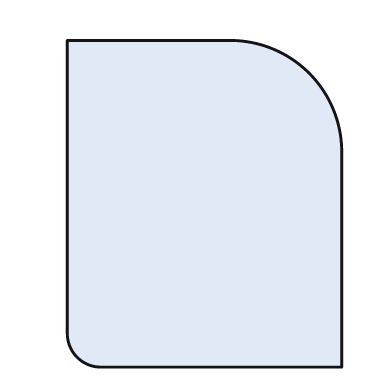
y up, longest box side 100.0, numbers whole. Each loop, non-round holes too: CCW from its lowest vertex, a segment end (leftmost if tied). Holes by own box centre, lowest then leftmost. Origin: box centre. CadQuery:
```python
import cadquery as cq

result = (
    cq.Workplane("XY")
    .moveTo(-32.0, -50.0)
    .lineTo(42.0, -50.0)
    .lineTo(42.0, 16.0)
    .threePointArc((32.0, 40.0), (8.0, 50.0))
    .lineTo(-42.0, 50.0)
    .lineTo(-42.0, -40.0)
    .threePointArc((-39.0, -47.0), (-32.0, -50.0))
    .close()
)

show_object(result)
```